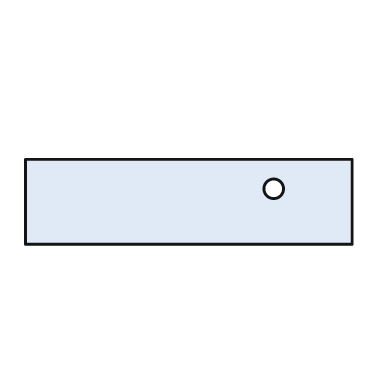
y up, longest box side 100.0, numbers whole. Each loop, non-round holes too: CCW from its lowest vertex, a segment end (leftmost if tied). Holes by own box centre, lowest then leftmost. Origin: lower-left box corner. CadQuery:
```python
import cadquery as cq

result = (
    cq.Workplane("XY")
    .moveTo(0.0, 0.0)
    .lineTo(100.0, 0.0)
    .lineTo(100.0, 26.0)
    .lineTo(0.0, 26.0)
    .close()
    .moveTo(76.0, 17.0)
    .circle(3.0)
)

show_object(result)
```